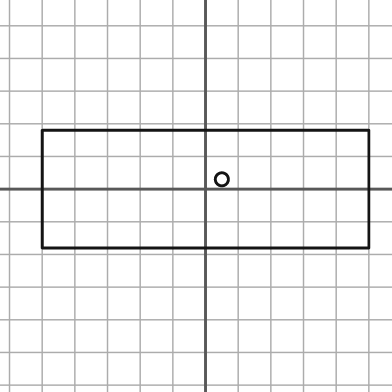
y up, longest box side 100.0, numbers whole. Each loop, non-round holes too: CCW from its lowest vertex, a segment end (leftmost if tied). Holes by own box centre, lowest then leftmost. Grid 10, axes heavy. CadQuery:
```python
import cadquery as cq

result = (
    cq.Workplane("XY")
    .moveTo(-50.0, -18.0)
    .lineTo(50.0, -18.0)
    .lineTo(50.0, 18.0)
    .lineTo(-50.0, 18.0)
    .close()
    .moveTo(5.0, 3.0)
    .circle(2.0)
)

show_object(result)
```